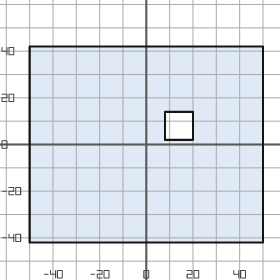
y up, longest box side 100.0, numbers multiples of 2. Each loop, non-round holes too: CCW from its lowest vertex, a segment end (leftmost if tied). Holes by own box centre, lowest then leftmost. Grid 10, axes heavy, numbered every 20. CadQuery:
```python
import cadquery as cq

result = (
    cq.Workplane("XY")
    .moveTo(-50.0, -42.0)
    .lineTo(50.0, -42.0)
    .lineTo(50.0, 42.0)
    .lineTo(-50.0, 42.0)
    .close()
    .moveTo(8.0, 2.0)
    .lineTo(20.0, 2.0)
    .lineTo(20.0, 14.0)
    .lineTo(8.0, 14.0)
    .close()
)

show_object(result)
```